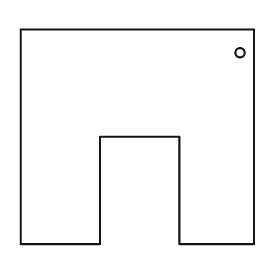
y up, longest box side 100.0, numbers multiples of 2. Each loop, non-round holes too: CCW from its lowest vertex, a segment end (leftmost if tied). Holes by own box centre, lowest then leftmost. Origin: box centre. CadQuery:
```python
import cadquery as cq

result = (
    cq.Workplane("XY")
    .moveTo(-50.0, -46.0)
    .lineTo(-16.0, -46.0)
    .lineTo(-16.0, 0.0)
    .lineTo(18.0, 0.0)
    .lineTo(18.0, -46.0)
    .lineTo(50.0, -46.0)
    .lineTo(50.0, 46.0)
    .lineTo(-50.0, 46.0)
    .close()
    .moveTo(44.0, 36.0)
    .circle(2.0)
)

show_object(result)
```